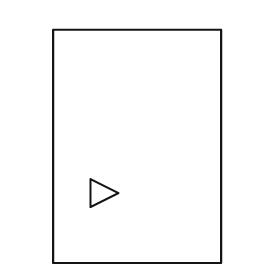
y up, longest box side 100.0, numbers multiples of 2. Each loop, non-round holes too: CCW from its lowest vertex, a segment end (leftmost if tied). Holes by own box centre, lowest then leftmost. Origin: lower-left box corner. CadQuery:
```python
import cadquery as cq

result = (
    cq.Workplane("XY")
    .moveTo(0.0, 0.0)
    .lineTo(72.0, 0.0)
    .lineTo(72.0, 100.0)
    .lineTo(0.0, 100.0)
    .close()
    .moveTo(16.0, 24.0)
    .lineTo(28.0, 30.0)
    .lineTo(16.0, 36.0)
    .close()
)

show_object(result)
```